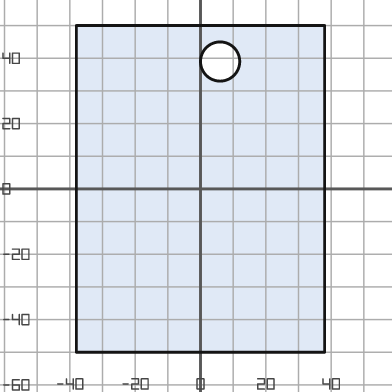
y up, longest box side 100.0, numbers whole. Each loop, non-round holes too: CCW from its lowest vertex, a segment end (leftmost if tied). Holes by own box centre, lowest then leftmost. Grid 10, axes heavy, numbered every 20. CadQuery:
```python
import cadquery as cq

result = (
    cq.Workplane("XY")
    .moveTo(-38.0, -50.0)
    .lineTo(38.0, -50.0)
    .lineTo(38.0, 50.0)
    .lineTo(-38.0, 50.0)
    .close()
    .moveTo(6.0, 39.0)
    .circle(6.0)
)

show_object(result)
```